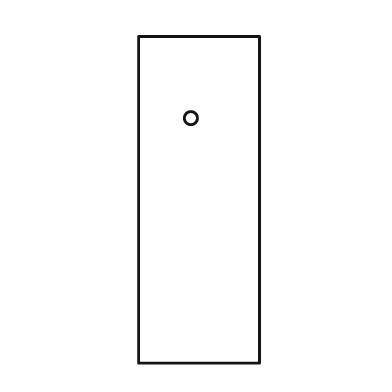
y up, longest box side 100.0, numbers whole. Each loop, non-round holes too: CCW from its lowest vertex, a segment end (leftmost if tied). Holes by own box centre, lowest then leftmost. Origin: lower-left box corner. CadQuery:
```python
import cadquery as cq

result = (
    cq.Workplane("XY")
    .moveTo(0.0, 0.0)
    .lineTo(37.0, 0.0)
    .lineTo(37.0, 100.0)
    .lineTo(0.0, 100.0)
    .close()
    .moveTo(16.0, 75.0)
    .circle(2.0)
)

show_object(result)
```